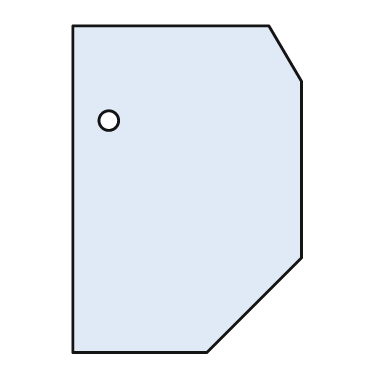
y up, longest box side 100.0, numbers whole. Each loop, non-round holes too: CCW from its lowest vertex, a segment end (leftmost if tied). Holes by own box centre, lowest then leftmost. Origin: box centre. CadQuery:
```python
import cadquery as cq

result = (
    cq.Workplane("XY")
    .moveTo(-35.0, -50.0)
    .lineTo(6.0, -50.0)
    .lineTo(35.0, -21.0)
    .lineTo(35.0, 33.0)
    .lineTo(25.0, 50.0)
    .lineTo(-35.0, 50.0)
    .close()
    .moveTo(-24.0, 21.0)
    .circle(3.0)
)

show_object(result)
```